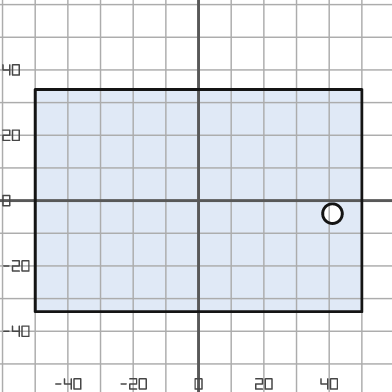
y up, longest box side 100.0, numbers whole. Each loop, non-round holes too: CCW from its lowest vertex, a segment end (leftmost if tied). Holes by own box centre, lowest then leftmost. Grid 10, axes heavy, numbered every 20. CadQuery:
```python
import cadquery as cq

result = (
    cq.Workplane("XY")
    .moveTo(-50.0, -34.0)
    .lineTo(50.0, -34.0)
    .lineTo(50.0, 34.0)
    .lineTo(-50.0, 34.0)
    .close()
    .moveTo(41.0, -4.0)
    .circle(3.0)
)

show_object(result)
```